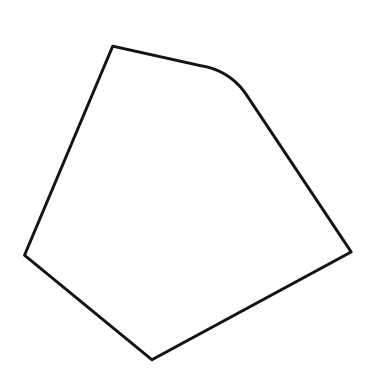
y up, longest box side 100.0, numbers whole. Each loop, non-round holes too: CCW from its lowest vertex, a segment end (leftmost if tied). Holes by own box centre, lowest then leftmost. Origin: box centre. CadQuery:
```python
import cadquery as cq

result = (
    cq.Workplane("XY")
    .moveTo(-11.0, -48.0)
    .lineTo(50.0, -15.0)
    .lineTo(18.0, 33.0)
    .threePointArc((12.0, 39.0), (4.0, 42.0))
    .lineTo(-23.0, 48.0)
    .lineTo(-50.0, -16.0)
    .close()
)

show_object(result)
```